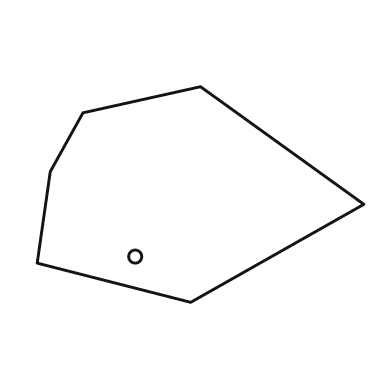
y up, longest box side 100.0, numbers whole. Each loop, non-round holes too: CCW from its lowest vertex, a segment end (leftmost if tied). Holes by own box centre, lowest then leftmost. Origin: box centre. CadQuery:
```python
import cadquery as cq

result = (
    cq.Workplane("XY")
    .moveTo(-3.0, -33.0)
    .lineTo(50.0, -3.0)
    .lineTo(0.0, 33.0)
    .lineTo(-36.0, 25.0)
    .lineTo(-46.0, 7.0)
    .lineTo(-50.0, -21.0)
    .close()
    .moveTo(-20.0, -19.0)
    .circle(2.0)
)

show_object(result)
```